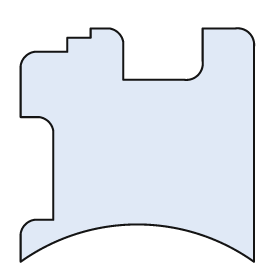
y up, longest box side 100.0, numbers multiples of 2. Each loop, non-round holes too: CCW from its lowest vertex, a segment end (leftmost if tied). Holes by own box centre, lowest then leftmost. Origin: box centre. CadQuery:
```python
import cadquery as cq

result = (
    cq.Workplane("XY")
    .moveTo(-50.0, -50.0)
    .threePointArc((0.0, -34.0), (50.0, -50.0))
    .lineTo(50.0, 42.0)
    .threePointArc((48.0, 48.0), (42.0, 50.0))
    .lineTo(28.0, 50.0)
    .lineTo(28.0, 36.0)
    .threePointArc((26.0, 30.0), (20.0, 28.0))
    .lineTo(-6.0, 28.0)
    .lineTo(-6.0, 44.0)
    .threePointArc((-8.0, 48.0), (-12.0, 50.0))
    .lineTo(-20.0, 50.0)
    .lineTo(-20.0, 46.0)
    .lineTo(-30.0, 46.0)
    .lineTo(-30.0, 40.0)
    .lineTo(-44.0, 40.0)
    .threePointArc((-48.0, 38.0), (-50.0, 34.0))
    .lineTo(-50.0, 12.0)
    .lineTo(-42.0, 12.0)
    .threePointArc((-38.0, 10.0), (-36.0, 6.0))
    .lineTo(-36.0, -32.0)
    .lineTo(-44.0, -32.0)
    .threePointArc((-48.0, -34.0), (-50.0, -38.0))
    .close()
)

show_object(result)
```